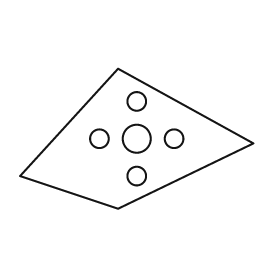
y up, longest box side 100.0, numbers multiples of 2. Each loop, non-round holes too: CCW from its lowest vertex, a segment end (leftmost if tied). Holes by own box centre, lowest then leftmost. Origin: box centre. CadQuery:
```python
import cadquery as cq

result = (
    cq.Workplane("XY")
    .moveTo(-8.0, -30.0)
    .lineTo(50.0, -2.0)
    .lineTo(-8.0, 30.0)
    .lineTo(-50.0, -16.0)
    .close()
    .moveTo(0.0, -16.0)
    .circle(4.0)
    .moveTo(-16.0, 0.0)
    .circle(4.0)
    .moveTo(0.0, 0.0)
    .circle(6.0)
    .moveTo(16.0, 0.0)
    .circle(4.0)
    .moveTo(0.0, 16.0)
    .circle(4.0)
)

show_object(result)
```